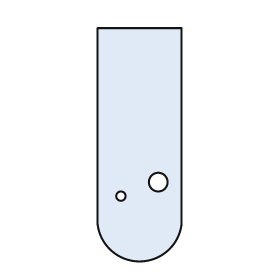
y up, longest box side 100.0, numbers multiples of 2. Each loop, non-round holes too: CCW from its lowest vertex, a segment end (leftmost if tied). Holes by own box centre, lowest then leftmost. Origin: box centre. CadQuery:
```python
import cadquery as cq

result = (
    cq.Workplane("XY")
    .moveTo(-18.0, -34.0)
    .threePointArc((0.0, -50.0), (18.0, -34.0))
    .lineTo(18.0, 50.0)
    .lineTo(-18.0, 50.0)
    .close()
    .moveTo(-8.0, -22.0)
    .circle(2.0)
    .moveTo(8.0, -16.0)
    .circle(4.0)
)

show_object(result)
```